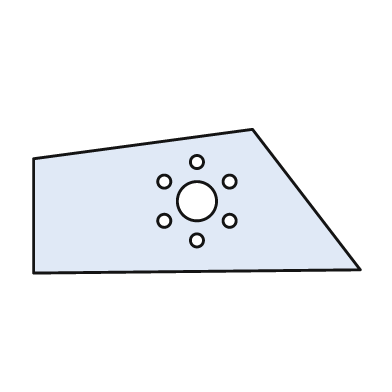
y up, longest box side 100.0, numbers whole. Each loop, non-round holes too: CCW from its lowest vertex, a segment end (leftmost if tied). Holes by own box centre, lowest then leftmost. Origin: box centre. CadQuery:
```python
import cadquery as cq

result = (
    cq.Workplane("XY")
    .moveTo(-50.0, -22.0)
    .lineTo(50.0, -21.0)
    .lineTo(17.0, 22.0)
    .lineTo(-50.0, 13.0)
    .close()
    .moveTo(0.0, -12.0)
    .circle(2.0)
    .moveTo(-10.0, -6.0)
    .circle(2.0)
    .moveTo(10.0, -6.0)
    .circle(2.0)
    .moveTo(0.0, 0.0)
    .circle(6.0)
    .moveTo(-10.0, 6.0)
    .circle(2.0)
    .moveTo(10.0, 6.0)
    .circle(2.0)
    .moveTo(0.0, 12.0)
    .circle(2.0)
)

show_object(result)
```